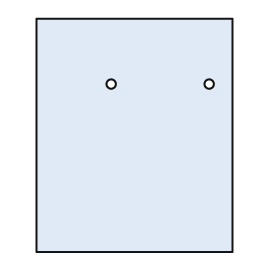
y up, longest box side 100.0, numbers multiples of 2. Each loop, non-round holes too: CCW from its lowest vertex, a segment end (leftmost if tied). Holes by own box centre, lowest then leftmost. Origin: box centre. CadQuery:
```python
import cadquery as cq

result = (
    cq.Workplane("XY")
    .moveTo(-42.0, -50.0)
    .lineTo(42.0, -50.0)
    .lineTo(42.0, 50.0)
    .lineTo(-42.0, 50.0)
    .close()
    .moveTo(-10.0, 22.0)
    .circle(2.0)
    .moveTo(32.0, 22.0)
    .circle(2.0)
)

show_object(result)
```